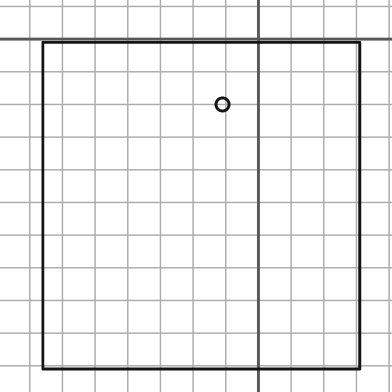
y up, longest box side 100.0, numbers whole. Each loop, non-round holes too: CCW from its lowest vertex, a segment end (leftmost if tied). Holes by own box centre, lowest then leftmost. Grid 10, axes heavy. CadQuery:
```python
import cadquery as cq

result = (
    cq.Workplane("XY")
    .moveTo(-66.0, -101.0)
    .lineTo(31.0, -101.0)
    .lineTo(31.0, -1.0)
    .lineTo(-66.0, -1.0)
    .close()
    .moveTo(-11.0, -20.0)
    .circle(2.0)
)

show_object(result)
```